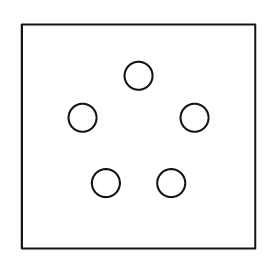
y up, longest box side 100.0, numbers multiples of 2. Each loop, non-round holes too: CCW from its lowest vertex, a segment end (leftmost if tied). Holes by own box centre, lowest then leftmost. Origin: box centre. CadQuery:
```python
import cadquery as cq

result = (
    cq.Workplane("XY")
    .moveTo(-50.0, -48.0)
    .lineTo(50.0, -48.0)
    .lineTo(50.0, 48.0)
    .lineTo(-50.0, 48.0)
    .close()
    .moveTo(-14.0, -20.0)
    .circle(6.0)
    .moveTo(14.0, -20.0)
    .circle(6.0)
    .moveTo(-24.0, 8.0)
    .circle(6.0)
    .moveTo(24.0, 8.0)
    .circle(6.0)
    .moveTo(0.0, 26.0)
    .circle(6.0)
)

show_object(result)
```